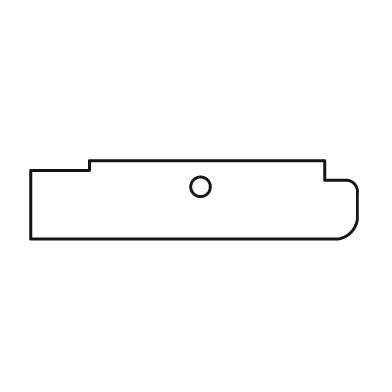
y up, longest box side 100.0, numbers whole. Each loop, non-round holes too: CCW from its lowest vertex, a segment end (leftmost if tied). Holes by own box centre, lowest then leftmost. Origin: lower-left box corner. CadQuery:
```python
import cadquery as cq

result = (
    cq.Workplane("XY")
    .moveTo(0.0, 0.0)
    .lineTo(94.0, 0.0)
    .threePointArc((98.0, 2.0), (100.0, 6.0))
    .lineTo(100.0, 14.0)
    .threePointArc((99.0, 17.0), (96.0, 18.0))
    .lineTo(90.0, 18.0)
    .lineTo(90.0, 24.0)
    .lineTo(18.0, 24.0)
    .lineTo(18.0, 21.0)
    .lineTo(0.0, 21.0)
    .close()
    .moveTo(52.0, 16.0)
    .circle(3.0)
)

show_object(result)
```